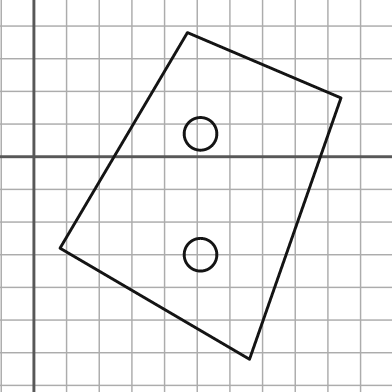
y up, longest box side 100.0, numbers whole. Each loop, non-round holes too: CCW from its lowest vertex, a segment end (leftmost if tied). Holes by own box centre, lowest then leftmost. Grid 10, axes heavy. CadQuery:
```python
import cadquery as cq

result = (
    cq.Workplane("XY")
    .moveTo(66.0, -62.0)
    .lineTo(94.0, 18.0)
    .lineTo(47.0, 38.0)
    .lineTo(8.0, -28.0)
    .close()
    .moveTo(51.0, -30.0)
    .circle(5.0)
    .moveTo(51.0, 7.0)
    .circle(5.0)
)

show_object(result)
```